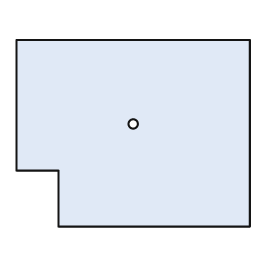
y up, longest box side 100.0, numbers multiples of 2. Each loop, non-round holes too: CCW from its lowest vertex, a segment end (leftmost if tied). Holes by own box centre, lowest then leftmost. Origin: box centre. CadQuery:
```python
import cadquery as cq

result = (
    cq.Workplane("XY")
    .moveTo(-32.0, -40.0)
    .lineTo(50.0, -40.0)
    .lineTo(50.0, 40.0)
    .lineTo(-50.0, 40.0)
    .lineTo(-50.0, -16.0)
    .lineTo(-32.0, -16.0)
    .close()
    .moveTo(0.0, 4.0)
    .circle(2.0)
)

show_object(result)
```